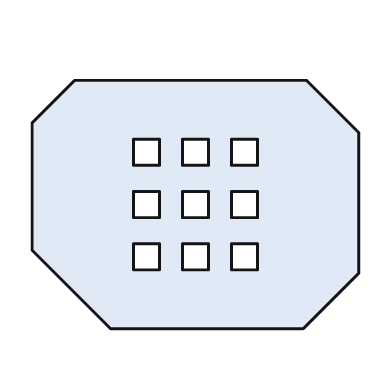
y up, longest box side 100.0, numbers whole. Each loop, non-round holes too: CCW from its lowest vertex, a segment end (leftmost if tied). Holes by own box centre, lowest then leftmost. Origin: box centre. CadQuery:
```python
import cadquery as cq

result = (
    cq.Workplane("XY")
    .moveTo(-26.0, -38.0)
    .lineTo(33.0, -38.0)
    .lineTo(50.0, -21.0)
    .lineTo(50.0, 22.0)
    .lineTo(34.0, 38.0)
    .lineTo(-37.0, 38.0)
    .lineTo(-50.0, 25.0)
    .lineTo(-50.0, -14.0)
    .close()
    .moveTo(-19.0, -20.0)
    .lineTo(-11.0, -20.0)
    .lineTo(-11.0, -12.0)
    .lineTo(-19.0, -12.0)
    .close()
    .moveTo(-4.0, -20.0)
    .lineTo(4.0, -20.0)
    .lineTo(4.0, -12.0)
    .lineTo(-4.0, -12.0)
    .close()
    .moveTo(11.0, -20.0)
    .lineTo(19.0, -20.0)
    .lineTo(19.0, -12.0)
    .lineTo(11.0, -12.0)
    .close()
    .moveTo(-19.0, -4.0)
    .lineTo(-11.0, -4.0)
    .lineTo(-11.0, 4.0)
    .lineTo(-19.0, 4.0)
    .close()
    .moveTo(-4.0, -4.0)
    .lineTo(4.0, -4.0)
    .lineTo(4.0, 4.0)
    .lineTo(-4.0, 4.0)
    .close()
    .moveTo(11.0, -4.0)
    .lineTo(19.0, -4.0)
    .lineTo(19.0, 4.0)
    .lineTo(11.0, 4.0)
    .close()
    .moveTo(-19.0, 12.0)
    .lineTo(-11.0, 12.0)
    .lineTo(-11.0, 20.0)
    .lineTo(-19.0, 20.0)
    .close()
    .moveTo(-4.0, 12.0)
    .lineTo(4.0, 12.0)
    .lineTo(4.0, 20.0)
    .lineTo(-4.0, 20.0)
    .close()
    .moveTo(11.0, 12.0)
    .lineTo(19.0, 12.0)
    .lineTo(19.0, 20.0)
    .lineTo(11.0, 20.0)
    .close()
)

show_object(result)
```